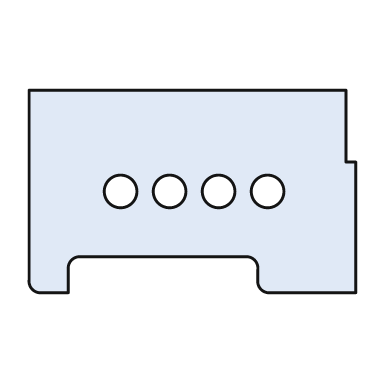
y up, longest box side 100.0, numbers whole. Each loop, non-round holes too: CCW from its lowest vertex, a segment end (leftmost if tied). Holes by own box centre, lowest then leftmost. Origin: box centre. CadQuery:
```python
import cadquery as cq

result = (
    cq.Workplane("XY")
    .moveTo(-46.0, -31.0)
    .lineTo(-38.0, -31.0)
    .lineTo(-38.0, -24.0)
    .threePointArc((-37.0, -21.0), (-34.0, -20.0))
    .lineTo(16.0, -20.0)
    .threePointArc((19.0, -21.0), (20.0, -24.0))
    .lineTo(20.0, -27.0)
    .threePointArc((21.0, -30.0), (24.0, -31.0))
    .lineTo(50.0, -31.0)
    .lineTo(50.0, 9.0)
    .lineTo(47.0, 9.0)
    .lineTo(47.0, 31.0)
    .lineTo(-50.0, 31.0)
    .lineTo(-50.0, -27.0)
    .threePointArc((-49.0, -30.0), (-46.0, -31.0))
    .close()
    .moveTo(-22.0, 0.0)
    .circle(5.0)
    .moveTo(-7.0, 0.0)
    .circle(5.0)
    .moveTo(8.0, 0.0)
    .circle(5.0)
    .moveTo(23.0, 0.0)
    .circle(5.0)
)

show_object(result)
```